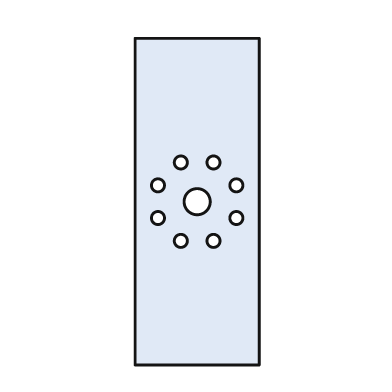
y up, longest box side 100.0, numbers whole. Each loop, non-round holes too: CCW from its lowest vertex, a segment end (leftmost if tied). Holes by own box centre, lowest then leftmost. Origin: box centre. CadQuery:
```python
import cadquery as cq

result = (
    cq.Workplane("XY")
    .moveTo(-19.0, -50.0)
    .lineTo(19.0, -50.0)
    .lineTo(19.0, 50.0)
    .lineTo(-19.0, 50.0)
    .close()
    .moveTo(-5.0, -12.0)
    .circle(2.0)
    .moveTo(5.0, -12.0)
    .circle(2.0)
    .moveTo(-12.0, -5.0)
    .circle(2.0)
    .moveTo(12.0, -5.0)
    .circle(2.0)
    .moveTo(0.0, 0.0)
    .circle(4.0)
    .moveTo(-12.0, 5.0)
    .circle(2.0)
    .moveTo(12.0, 5.0)
    .circle(2.0)
    .moveTo(-5.0, 12.0)
    .circle(2.0)
    .moveTo(5.0, 12.0)
    .circle(2.0)
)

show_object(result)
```